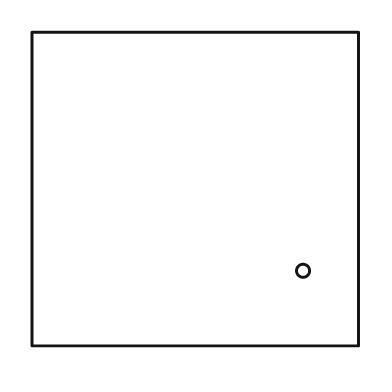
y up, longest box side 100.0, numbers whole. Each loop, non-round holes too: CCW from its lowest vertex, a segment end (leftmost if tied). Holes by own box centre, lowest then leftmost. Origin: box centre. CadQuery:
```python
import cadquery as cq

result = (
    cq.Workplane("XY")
    .moveTo(-50.0, -48.0)
    .lineTo(50.0, -48.0)
    .lineTo(50.0, 48.0)
    .lineTo(-50.0, 48.0)
    .close()
    .moveTo(33.0, -25.0)
    .circle(2.0)
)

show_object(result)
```